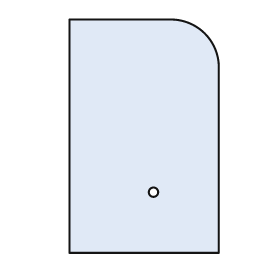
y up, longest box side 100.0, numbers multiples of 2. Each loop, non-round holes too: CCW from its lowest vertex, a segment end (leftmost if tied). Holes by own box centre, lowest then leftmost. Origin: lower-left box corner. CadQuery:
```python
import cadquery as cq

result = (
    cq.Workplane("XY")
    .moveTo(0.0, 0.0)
    .lineTo(64.0, 0.0)
    .lineTo(64.0, 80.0)
    .threePointArc((58.0, 94.0), (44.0, 100.0))
    .lineTo(0.0, 100.0)
    .close()
    .moveTo(36.0, 26.0)
    .circle(2.0)
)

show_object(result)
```